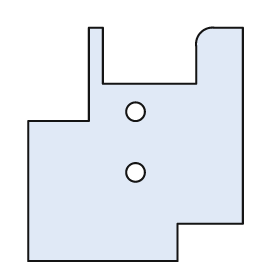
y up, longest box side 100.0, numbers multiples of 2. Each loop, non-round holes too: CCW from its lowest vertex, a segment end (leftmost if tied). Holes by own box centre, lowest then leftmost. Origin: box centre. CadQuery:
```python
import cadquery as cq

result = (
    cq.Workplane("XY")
    .moveTo(-46.0, -50.0)
    .lineTo(18.0, -50.0)
    .lineTo(18.0, -34.0)
    .lineTo(46.0, -34.0)
    .lineTo(46.0, 50.0)
    .lineTo(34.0, 50.0)
    .threePointArc((28.0, 48.0), (26.0, 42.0))
    .lineTo(26.0, 26.0)
    .lineTo(-14.0, 26.0)
    .lineTo(-14.0, 50.0)
    .lineTo(-20.0, 50.0)
    .lineTo(-20.0, 10.0)
    .lineTo(-46.0, 10.0)
    .close()
    .moveTo(0.0, -12.0)
    .circle(4.0)
    .moveTo(0.0, 14.0)
    .circle(4.0)
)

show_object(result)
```